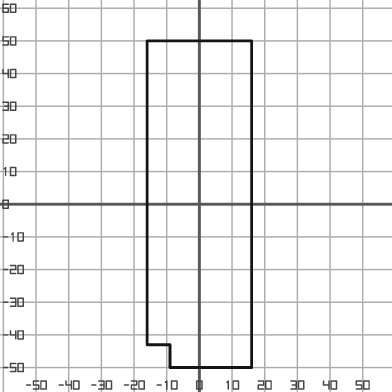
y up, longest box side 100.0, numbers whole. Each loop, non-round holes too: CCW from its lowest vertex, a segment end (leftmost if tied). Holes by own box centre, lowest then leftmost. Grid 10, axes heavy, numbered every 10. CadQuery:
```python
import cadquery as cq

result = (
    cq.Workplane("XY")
    .moveTo(-9.0, -50.0)
    .lineTo(16.0, -50.0)
    .lineTo(16.0, 50.0)
    .lineTo(-16.0, 50.0)
    .lineTo(-16.0, -43.0)
    .lineTo(-9.0, -43.0)
    .close()
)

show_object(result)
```